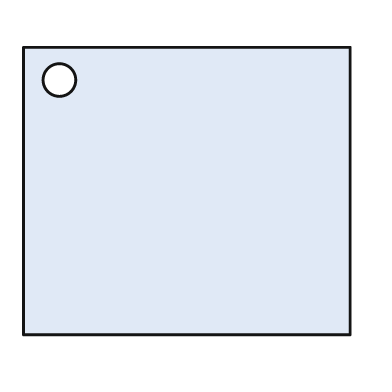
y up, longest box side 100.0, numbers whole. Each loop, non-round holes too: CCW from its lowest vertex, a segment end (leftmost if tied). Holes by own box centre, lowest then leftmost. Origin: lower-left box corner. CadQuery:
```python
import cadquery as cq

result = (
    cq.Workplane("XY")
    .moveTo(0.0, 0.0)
    .lineTo(100.0, 0.0)
    .lineTo(100.0, 88.0)
    .lineTo(0.0, 88.0)
    .close()
    .moveTo(11.0, 78.0)
    .circle(5.0)
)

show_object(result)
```